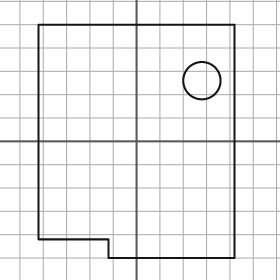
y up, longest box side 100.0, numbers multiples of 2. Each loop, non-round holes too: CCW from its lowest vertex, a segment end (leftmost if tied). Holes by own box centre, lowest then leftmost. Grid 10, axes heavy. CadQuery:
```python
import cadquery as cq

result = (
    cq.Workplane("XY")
    .moveTo(-12.0, -50.0)
    .lineTo(42.0, -50.0)
    .lineTo(42.0, 50.0)
    .lineTo(-42.0, 50.0)
    .lineTo(-42.0, -42.0)
    .lineTo(-12.0, -42.0)
    .close()
    .moveTo(28.0, 26.0)
    .circle(8.0)
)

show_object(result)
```